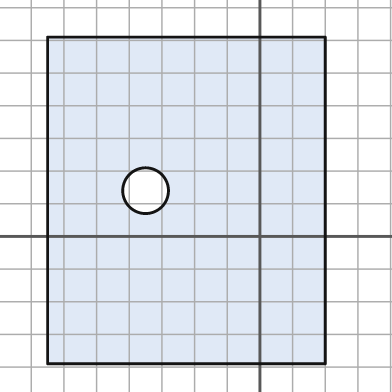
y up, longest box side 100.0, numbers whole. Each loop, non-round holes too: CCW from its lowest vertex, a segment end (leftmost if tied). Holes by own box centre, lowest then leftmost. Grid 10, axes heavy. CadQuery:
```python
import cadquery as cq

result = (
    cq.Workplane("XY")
    .moveTo(-65.0, -39.0)
    .lineTo(20.0, -39.0)
    .lineTo(20.0, 61.0)
    .lineTo(-65.0, 61.0)
    .close()
    .moveTo(-35.0, 14.0)
    .circle(7.0)
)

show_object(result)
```